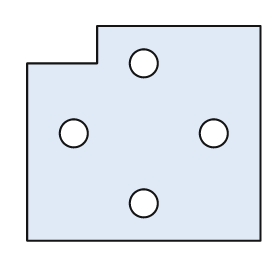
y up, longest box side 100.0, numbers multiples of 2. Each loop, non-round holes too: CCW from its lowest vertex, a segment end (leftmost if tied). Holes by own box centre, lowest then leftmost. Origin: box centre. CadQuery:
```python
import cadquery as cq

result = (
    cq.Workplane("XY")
    .moveTo(-50.0, -46.0)
    .lineTo(50.0, -46.0)
    .lineTo(50.0, 46.0)
    .lineTo(-20.0, 46.0)
    .lineTo(-20.0, 30.0)
    .lineTo(-50.0, 30.0)
    .close()
    .moveTo(0.0, -30.0)
    .circle(6.0)
    .moveTo(-30.0, 0.0)
    .circle(6.0)
    .moveTo(30.0, 0.0)
    .circle(6.0)
    .moveTo(0.0, 30.0)
    .circle(6.0)
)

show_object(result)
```